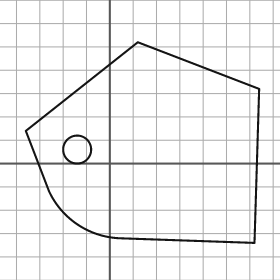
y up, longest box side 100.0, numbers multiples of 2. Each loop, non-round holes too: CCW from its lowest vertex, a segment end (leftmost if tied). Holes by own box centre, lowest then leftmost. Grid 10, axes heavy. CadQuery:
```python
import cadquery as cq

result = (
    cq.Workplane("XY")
    .moveTo(62.0, -34.0)
    .lineTo(64.0, 32.0)
    .lineTo(12.0, 52.0)
    .lineTo(-36.0, 14.0)
    .lineTo(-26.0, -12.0)
    .threePointArc((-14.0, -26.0), (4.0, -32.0))
    .close()
    .moveTo(-14.0, 6.0)
    .circle(6.0)
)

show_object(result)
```